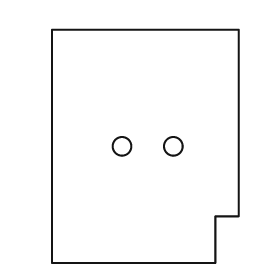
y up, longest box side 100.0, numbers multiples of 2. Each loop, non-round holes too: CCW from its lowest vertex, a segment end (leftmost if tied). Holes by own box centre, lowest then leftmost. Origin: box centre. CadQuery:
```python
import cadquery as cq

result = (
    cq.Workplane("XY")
    .moveTo(-40.0, -50.0)
    .lineTo(30.0, -50.0)
    .lineTo(30.0, -30.0)
    .lineTo(40.0, -30.0)
    .lineTo(40.0, 50.0)
    .lineTo(-40.0, 50.0)
    .close()
    .moveTo(-10.0, 0.0)
    .circle(4.0)
    .moveTo(12.0, 0.0)
    .circle(4.0)
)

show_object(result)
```